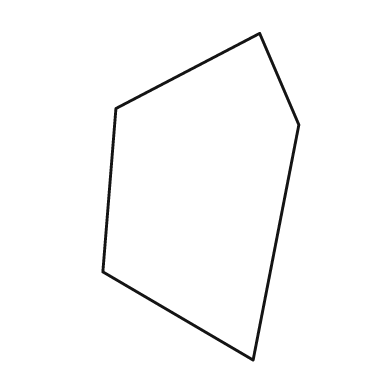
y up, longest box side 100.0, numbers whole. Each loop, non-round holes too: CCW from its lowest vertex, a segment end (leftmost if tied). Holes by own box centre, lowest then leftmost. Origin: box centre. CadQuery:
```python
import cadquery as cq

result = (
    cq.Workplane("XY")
    .moveTo(16.0, -50.0)
    .lineTo(30.0, 22.0)
    .lineTo(18.0, 50.0)
    .lineTo(-26.0, 27.0)
    .lineTo(-30.0, -23.0)
    .close()
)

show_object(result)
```